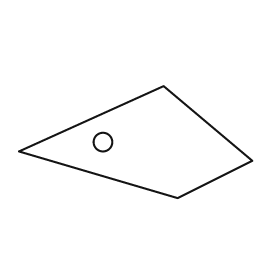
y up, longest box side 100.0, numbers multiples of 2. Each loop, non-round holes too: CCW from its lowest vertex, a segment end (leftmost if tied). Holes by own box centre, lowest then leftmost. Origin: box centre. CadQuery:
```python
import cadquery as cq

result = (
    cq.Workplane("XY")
    .moveTo(18.0, -24.0)
    .lineTo(50.0, -8.0)
    .lineTo(12.0, 24.0)
    .lineTo(-50.0, -4.0)
    .close()
    .moveTo(-14.0, 0.0)
    .circle(4.0)
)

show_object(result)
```